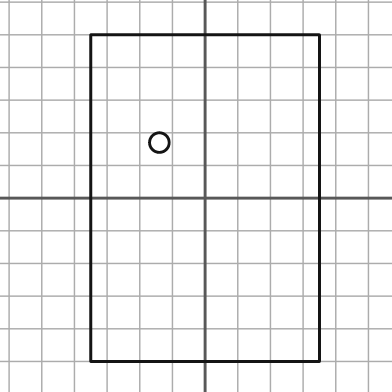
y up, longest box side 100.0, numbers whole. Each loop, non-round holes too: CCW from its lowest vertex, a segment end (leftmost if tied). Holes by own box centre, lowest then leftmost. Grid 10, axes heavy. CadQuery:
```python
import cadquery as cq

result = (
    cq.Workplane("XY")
    .moveTo(-35.0, -50.0)
    .lineTo(35.0, -50.0)
    .lineTo(35.0, 50.0)
    .lineTo(-35.0, 50.0)
    .close()
    .moveTo(-14.0, 17.0)
    .circle(3.0)
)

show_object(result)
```